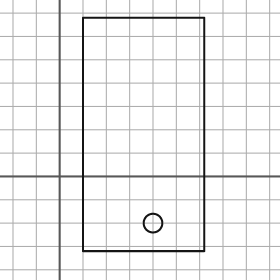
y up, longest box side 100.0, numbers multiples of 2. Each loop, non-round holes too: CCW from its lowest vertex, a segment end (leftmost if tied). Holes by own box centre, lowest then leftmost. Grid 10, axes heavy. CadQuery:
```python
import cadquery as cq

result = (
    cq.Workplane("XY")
    .moveTo(10.0, -32.0)
    .lineTo(62.0, -32.0)
    .lineTo(62.0, 68.0)
    .lineTo(10.0, 68.0)
    .close()
    .moveTo(40.0, -20.0)
    .circle(4.0)
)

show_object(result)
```